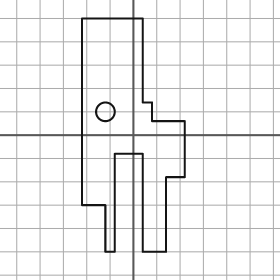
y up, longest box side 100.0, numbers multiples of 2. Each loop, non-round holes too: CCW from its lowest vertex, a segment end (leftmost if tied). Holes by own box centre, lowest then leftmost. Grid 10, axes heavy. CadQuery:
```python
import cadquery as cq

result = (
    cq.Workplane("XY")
    .moveTo(-12.0, -50.0)
    .lineTo(-8.0, -50.0)
    .lineTo(-8.0, -8.0)
    .lineTo(4.0, -8.0)
    .lineTo(4.0, -50.0)
    .lineTo(14.0, -50.0)
    .lineTo(14.0, -18.0)
    .lineTo(22.0, -18.0)
    .lineTo(22.0, 6.0)
    .lineTo(8.0, 6.0)
    .lineTo(8.0, 14.0)
    .lineTo(4.0, 14.0)
    .lineTo(4.0, 50.0)
    .lineTo(-22.0, 50.0)
    .lineTo(-22.0, -30.0)
    .lineTo(-12.0, -30.0)
    .close()
    .moveTo(-12.0, 10.0)
    .circle(4.0)
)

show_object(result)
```